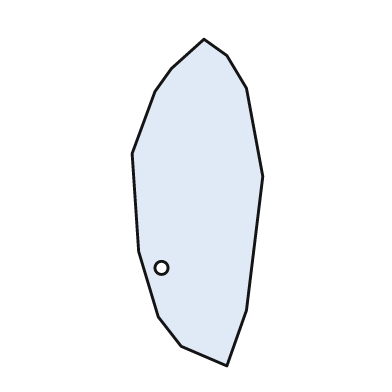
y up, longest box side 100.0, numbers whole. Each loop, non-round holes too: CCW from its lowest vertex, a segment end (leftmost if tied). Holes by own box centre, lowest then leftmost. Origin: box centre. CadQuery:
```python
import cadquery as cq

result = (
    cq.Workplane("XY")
    .moveTo(9.0, -50.0)
    .lineTo(15.0, -33.0)
    .lineTo(20.0, 8.0)
    .lineTo(15.0, 35.0)
    .lineTo(9.0, 45.0)
    .lineTo(2.0, 50.0)
    .lineTo(-8.0, 41.0)
    .lineTo(-13.0, 34.0)
    .lineTo(-20.0, 15.0)
    .lineTo(-18.0, -15.0)
    .lineTo(-12.0, -35.0)
    .lineTo(-5.0, -44.0)
    .close()
    .moveTo(-11.0, -20.0)
    .circle(2.0)
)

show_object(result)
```